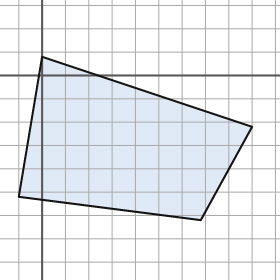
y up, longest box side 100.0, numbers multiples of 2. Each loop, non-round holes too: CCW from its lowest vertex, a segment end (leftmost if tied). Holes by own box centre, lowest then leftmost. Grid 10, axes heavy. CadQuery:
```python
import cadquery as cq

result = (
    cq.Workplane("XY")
    .moveTo(68.0, -62.0)
    .lineTo(90.0, -22.0)
    .lineTo(0.0, 8.0)
    .lineTo(-10.0, -52.0)
    .close()
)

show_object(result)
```